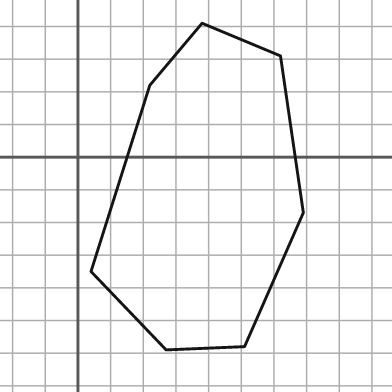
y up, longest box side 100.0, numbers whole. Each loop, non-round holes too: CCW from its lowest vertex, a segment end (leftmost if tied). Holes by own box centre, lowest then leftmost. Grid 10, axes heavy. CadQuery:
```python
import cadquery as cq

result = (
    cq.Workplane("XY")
    .moveTo(27.0, -59.0)
    .lineTo(51.0, -58.0)
    .lineTo(69.0, -17.0)
    .lineTo(62.0, 31.0)
    .lineTo(38.0, 41.0)
    .lineTo(22.0, 22.0)
    .lineTo(4.0, -35.0)
    .close()
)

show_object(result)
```